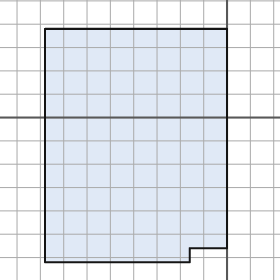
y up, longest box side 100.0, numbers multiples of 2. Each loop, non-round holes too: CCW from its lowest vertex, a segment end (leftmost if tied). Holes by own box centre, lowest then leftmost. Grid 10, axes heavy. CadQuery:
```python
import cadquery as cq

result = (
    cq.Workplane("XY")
    .moveTo(-78.0, -62.0)
    .lineTo(-16.0, -62.0)
    .lineTo(-16.0, -56.0)
    .lineTo(0.0, -56.0)
    .lineTo(0.0, 38.0)
    .lineTo(-78.0, 38.0)
    .close()
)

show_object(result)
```